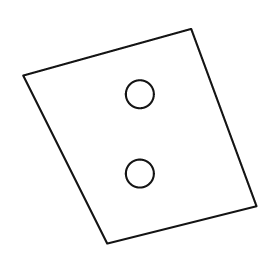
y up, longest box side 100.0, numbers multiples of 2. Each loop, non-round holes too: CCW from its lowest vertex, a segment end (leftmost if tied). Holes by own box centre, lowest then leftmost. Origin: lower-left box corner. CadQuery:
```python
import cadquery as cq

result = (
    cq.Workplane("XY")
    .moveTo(36.0, 0.0)
    .lineTo(100.0, 16.0)
    .lineTo(72.0, 92.0)
    .lineTo(0.0, 72.0)
    .close()
    .moveTo(50.0, 30.0)
    .circle(6.0)
    .moveTo(50.0, 64.0)
    .circle(6.0)
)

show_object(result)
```